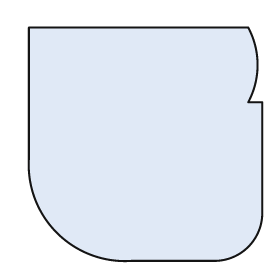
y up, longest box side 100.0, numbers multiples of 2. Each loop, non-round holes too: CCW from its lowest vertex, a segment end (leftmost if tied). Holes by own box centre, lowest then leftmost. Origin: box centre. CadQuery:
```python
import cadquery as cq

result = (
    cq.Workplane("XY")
    .moveTo(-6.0, -50.0)
    .lineTo(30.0, -50.0)
    .threePointArc((44.0, -44.0), (50.0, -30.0))
    .lineTo(50.0, 18.0)
    .lineTo(44.0, 18.0)
    .threePointArc((48.0, 34.0), (44.0, 50.0))
    .lineTo(-50.0, 50.0)
    .lineTo(-50.0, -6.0)
    .threePointArc((-38.0, -38.0), (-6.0, -50.0))
    .close()
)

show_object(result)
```